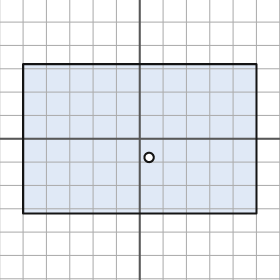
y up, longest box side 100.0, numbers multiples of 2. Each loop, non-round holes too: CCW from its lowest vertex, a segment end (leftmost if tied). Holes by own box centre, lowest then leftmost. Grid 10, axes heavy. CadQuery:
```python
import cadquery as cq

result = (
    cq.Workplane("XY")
    .moveTo(-50.0, -32.0)
    .lineTo(50.0, -32.0)
    .lineTo(50.0, 32.0)
    .lineTo(-50.0, 32.0)
    .close()
    .moveTo(4.0, -8.0)
    .circle(2.0)
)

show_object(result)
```